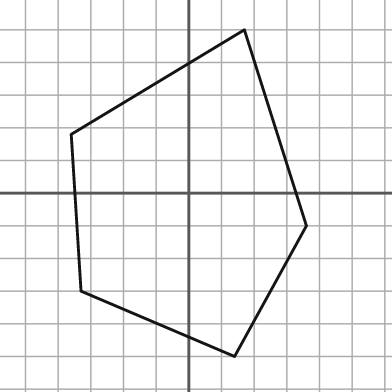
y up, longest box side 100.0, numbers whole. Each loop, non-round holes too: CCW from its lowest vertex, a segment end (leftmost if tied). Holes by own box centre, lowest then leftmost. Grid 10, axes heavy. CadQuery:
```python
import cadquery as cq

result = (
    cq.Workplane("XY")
    .moveTo(14.0, -50.0)
    .lineTo(36.0, -10.0)
    .lineTo(17.0, 50.0)
    .lineTo(-36.0, 18.0)
    .lineTo(-33.0, -30.0)
    .close()
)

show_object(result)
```